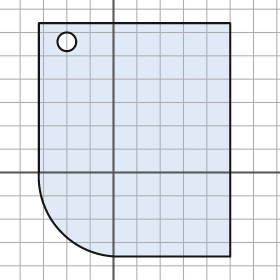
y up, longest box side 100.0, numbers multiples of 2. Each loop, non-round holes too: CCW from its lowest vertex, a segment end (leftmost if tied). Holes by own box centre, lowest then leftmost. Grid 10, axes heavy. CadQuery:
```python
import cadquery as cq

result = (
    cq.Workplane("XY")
    .moveTo(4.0, -36.0)
    .lineTo(50.0, -36.0)
    .lineTo(50.0, 64.0)
    .lineTo(-32.0, 64.0)
    .lineTo(-32.0, 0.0)
    .threePointArc((-22.0, -26.0), (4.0, -36.0))
    .close()
    .moveTo(-20.0, 56.0)
    .circle(4.0)
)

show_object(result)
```